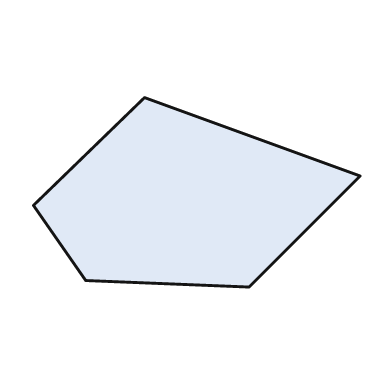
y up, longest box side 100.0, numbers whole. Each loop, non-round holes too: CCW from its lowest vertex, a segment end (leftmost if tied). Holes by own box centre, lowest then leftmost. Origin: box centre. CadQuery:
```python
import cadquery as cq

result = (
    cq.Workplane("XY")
    .moveTo(16.0, -29.0)
    .lineTo(50.0, 5.0)
    .lineTo(-16.0, 29.0)
    .lineTo(-50.0, -4.0)
    .lineTo(-34.0, -27.0)
    .close()
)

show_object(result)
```